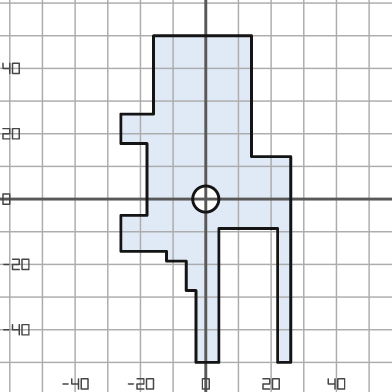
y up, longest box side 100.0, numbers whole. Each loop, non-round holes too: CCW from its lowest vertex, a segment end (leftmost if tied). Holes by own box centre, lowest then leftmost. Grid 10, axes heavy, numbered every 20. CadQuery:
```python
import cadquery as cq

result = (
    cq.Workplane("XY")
    .moveTo(-3.0, -50.0)
    .lineTo(4.0, -50.0)
    .lineTo(4.0, -9.0)
    .lineTo(22.0, -9.0)
    .lineTo(22.0, -50.0)
    .lineTo(26.0, -50.0)
    .lineTo(26.0, 13.0)
    .lineTo(14.0, 13.0)
    .lineTo(14.0, 50.0)
    .lineTo(-16.0, 50.0)
    .lineTo(-16.0, 26.0)
    .lineTo(-26.0, 26.0)
    .lineTo(-26.0, 17.0)
    .lineTo(-18.0, 17.0)
    .lineTo(-18.0, -5.0)
    .lineTo(-26.0, -5.0)
    .lineTo(-26.0, -16.0)
    .lineTo(-12.0, -16.0)
    .lineTo(-12.0, -19.0)
    .lineTo(-6.0, -19.0)
    .lineTo(-6.0, -28.0)
    .lineTo(-3.0, -28.0)
    .close()
    .moveTo(0.0, 0.0)
    .circle(4.0)
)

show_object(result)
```